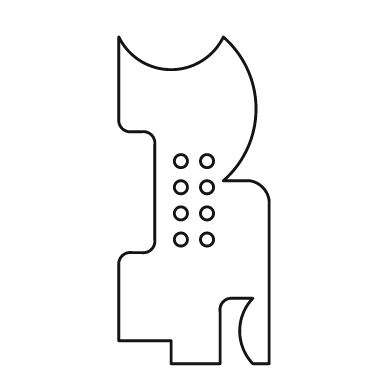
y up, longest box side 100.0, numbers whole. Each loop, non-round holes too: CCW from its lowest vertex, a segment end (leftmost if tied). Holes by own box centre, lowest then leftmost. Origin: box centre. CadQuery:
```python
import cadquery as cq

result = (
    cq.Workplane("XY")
    .moveTo(-7.0, -50.0)
    .lineTo(8.0, -50.0)
    .lineTo(8.0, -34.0)
    .threePointArc((9.0, -31.0), (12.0, -30.0))
    .lineTo(18.0, -30.0)
    .threePointArc((14.0, -40.0), (18.0, -50.0))
    .lineTo(23.0, -50.0)
    .lineTo(23.0, 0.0)
    .threePointArc((21.0, 4.0), (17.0, 6.0))
    .lineTo(9.0, 6.0)
    .threePointArc((19.0, 28.0), (9.0, 50.0))
    .threePointArc((-7.0, 40.0), (-23.0, 50.0))
    .lineTo(-23.0, 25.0)
    .threePointArc((-22.0, 22.0), (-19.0, 21.0))
    .lineTo(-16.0, 21.0)
    .threePointArc((-13.0, 20.0), (-12.0, 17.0))
    .lineTo(-12.0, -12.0)
    .threePointArc((-13.0, -15.0), (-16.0, -16.0))
    .lineTo(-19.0, -16.0)
    .threePointArc((-22.0, -17.0), (-23.0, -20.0))
    .lineTo(-23.0, -43.0)
    .lineTo(-7.0, -43.0)
    .close()
    .moveTo(-4.0, -12.0)
    .circle(2.0)
    .moveTo(4.0, -12.0)
    .circle(2.0)
    .moveTo(-4.0, -4.0)
    .circle(2.0)
    .moveTo(4.0, -4.0)
    .circle(2.0)
    .moveTo(-4.0, 4.0)
    .circle(2.0)
    .moveTo(4.0, 4.0)
    .circle(2.0)
    .moveTo(-4.0, 12.0)
    .circle(2.0)
    .moveTo(4.0, 12.0)
    .circle(2.0)
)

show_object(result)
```